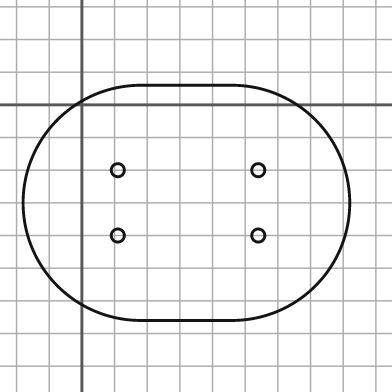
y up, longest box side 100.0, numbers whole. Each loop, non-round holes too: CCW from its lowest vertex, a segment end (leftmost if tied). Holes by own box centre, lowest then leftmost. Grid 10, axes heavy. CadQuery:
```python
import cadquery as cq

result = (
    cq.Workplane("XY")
    .moveTo(18.0, -66.0)
    .lineTo(46.0, -66.0)
    .threePointArc((82.0, -30.0), (46.0, 6.0))
    .lineTo(18.0, 6.0)
    .threePointArc((-18.0, -30.0), (18.0, -66.0))
    .close()
    .moveTo(11.0, -40.0)
    .circle(2.0)
    .moveTo(54.0, -40.0)
    .circle(2.0)
    .moveTo(11.0, -20.0)
    .circle(2.0)
    .moveTo(54.0, -20.0)
    .circle(2.0)
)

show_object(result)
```